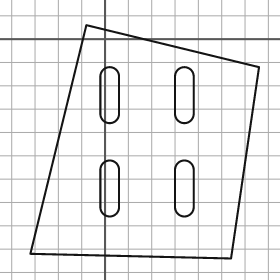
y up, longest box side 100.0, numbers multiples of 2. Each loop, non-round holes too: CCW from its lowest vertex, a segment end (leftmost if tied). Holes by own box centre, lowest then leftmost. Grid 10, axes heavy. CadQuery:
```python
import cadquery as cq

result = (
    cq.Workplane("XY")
    .moveTo(54.0, -94.0)
    .lineTo(66.0, -12.0)
    .lineTo(-8.0, 6.0)
    .lineTo(-32.0, -92.0)
    .close()
    .moveTo(-2.0, -72.0)
    .threePointArc((2.0, -76.0), (6.0, -72.0))
    .lineTo(6.0, -56.0)
    .threePointArc((2.0, -52.0), (-2.0, -56.0))
    .close()
    .moveTo(30.0, -72.0)
    .threePointArc((34.0, -76.0), (38.0, -72.0))
    .lineTo(38.0, -56.0)
    .threePointArc((34.0, -52.0), (30.0, -56.0))
    .close()
    .moveTo(-2.0, -32.0)
    .threePointArc((2.0, -36.0), (6.0, -32.0))
    .lineTo(6.0, -16.0)
    .threePointArc((2.0, -12.0), (-2.0, -16.0))
    .close()
    .moveTo(30.0, -32.0)
    .threePointArc((34.0, -36.0), (38.0, -32.0))
    .lineTo(38.0, -16.0)
    .threePointArc((34.0, -12.0), (30.0, -16.0))
    .close()
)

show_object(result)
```